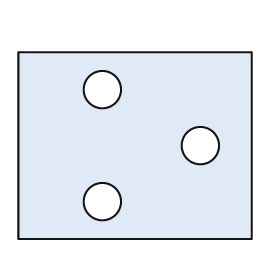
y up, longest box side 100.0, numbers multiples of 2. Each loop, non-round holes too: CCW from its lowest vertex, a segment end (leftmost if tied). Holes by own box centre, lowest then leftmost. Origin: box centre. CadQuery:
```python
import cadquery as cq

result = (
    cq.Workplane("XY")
    .moveTo(-50.0, -40.0)
    .lineTo(50.0, -40.0)
    .lineTo(50.0, 40.0)
    .lineTo(-50.0, 40.0)
    .close()
    .moveTo(-14.0, -24.0)
    .circle(8.0)
    .moveTo(28.0, 0.0)
    .circle(8.0)
    .moveTo(-14.0, 24.0)
    .circle(8.0)
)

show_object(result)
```